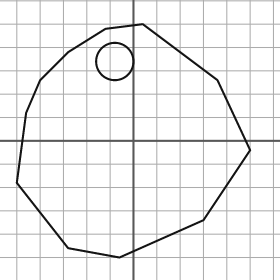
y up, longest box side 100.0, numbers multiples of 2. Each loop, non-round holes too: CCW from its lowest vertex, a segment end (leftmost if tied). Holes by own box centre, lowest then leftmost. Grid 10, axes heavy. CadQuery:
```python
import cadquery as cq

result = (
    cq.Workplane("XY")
    .moveTo(-6.0, -50.0)
    .lineTo(30.0, -34.0)
    .lineTo(50.0, -4.0)
    .lineTo(36.0, 26.0)
    .lineTo(4.0, 50.0)
    .lineTo(-12.0, 48.0)
    .lineTo(-28.0, 38.0)
    .lineTo(-40.0, 26.0)
    .lineTo(-46.0, 12.0)
    .lineTo(-50.0, -18.0)
    .lineTo(-28.0, -46.0)
    .close()
    .moveTo(-8.0, 34.0)
    .circle(8.0)
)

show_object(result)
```